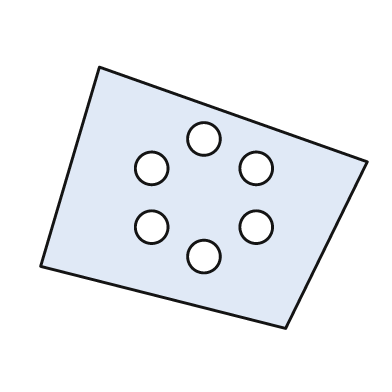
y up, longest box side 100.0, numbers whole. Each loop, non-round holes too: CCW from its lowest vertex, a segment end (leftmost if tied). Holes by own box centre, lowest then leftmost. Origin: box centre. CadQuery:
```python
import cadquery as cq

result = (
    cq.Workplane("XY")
    .moveTo(25.0, -40.0)
    .lineTo(50.0, 11.0)
    .lineTo(-32.0, 40.0)
    .lineTo(-50.0, -21.0)
    .close()
    .moveTo(0.0, -18.0)
    .circle(5.0)
    .moveTo(-16.0, -9.0)
    .circle(5.0)
    .moveTo(16.0, -9.0)
    .circle(5.0)
    .moveTo(-16.0, 9.0)
    .circle(5.0)
    .moveTo(16.0, 9.0)
    .circle(5.0)
    .moveTo(0.0, 18.0)
    .circle(5.0)
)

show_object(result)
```